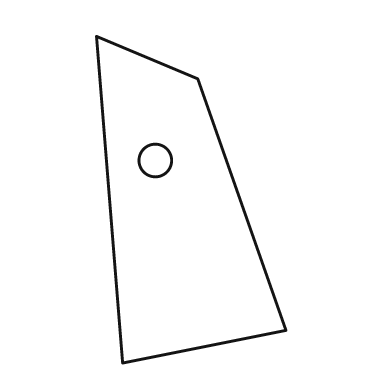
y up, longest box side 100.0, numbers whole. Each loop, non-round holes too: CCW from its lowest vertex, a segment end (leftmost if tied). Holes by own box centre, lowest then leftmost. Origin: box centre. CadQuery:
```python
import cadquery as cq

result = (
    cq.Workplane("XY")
    .moveTo(-21.0, -50.0)
    .lineTo(29.0, -40.0)
    .lineTo(2.0, 37.0)
    .lineTo(-29.0, 50.0)
    .close()
    .moveTo(-11.0, 12.0)
    .circle(5.0)
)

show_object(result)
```